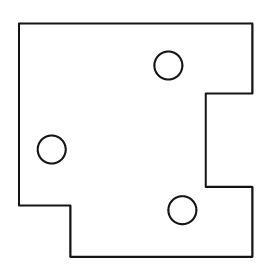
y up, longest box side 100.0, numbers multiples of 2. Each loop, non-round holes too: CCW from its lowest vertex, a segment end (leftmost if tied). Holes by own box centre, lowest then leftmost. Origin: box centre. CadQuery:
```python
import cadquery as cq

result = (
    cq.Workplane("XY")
    .moveTo(-28.0, -50.0)
    .lineTo(50.0, -50.0)
    .lineTo(50.0, -20.0)
    .lineTo(30.0, -20.0)
    .lineTo(30.0, 20.0)
    .lineTo(50.0, 20.0)
    .lineTo(50.0, 50.0)
    .lineTo(-50.0, 50.0)
    .lineTo(-50.0, -28.0)
    .lineTo(-28.0, -28.0)
    .close()
    .moveTo(20.0, -30.0)
    .circle(6.0)
    .moveTo(-36.0, -4.0)
    .circle(6.0)
    .moveTo(14.0, 32.0)
    .circle(6.0)
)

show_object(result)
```